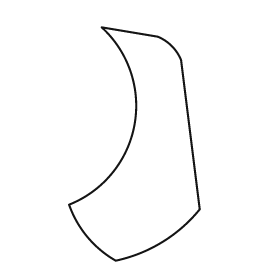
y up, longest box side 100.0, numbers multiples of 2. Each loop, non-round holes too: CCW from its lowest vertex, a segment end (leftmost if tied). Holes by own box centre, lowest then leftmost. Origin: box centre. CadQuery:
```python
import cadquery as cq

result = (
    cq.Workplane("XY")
    .moveTo(-8.0, -50.0)
    .threePointArc((12.0, -42.0), (28.0, -28.0))
    .lineTo(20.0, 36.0)
    .threePointArc((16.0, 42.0), (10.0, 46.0))
    .lineTo(-14.0, 50.0)
    .threePointArc((0.0, 8.0), (-28.0, -26.0))
    .threePointArc((-20.0, -40.0), (-8.0, -50.0))
    .close()
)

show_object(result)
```